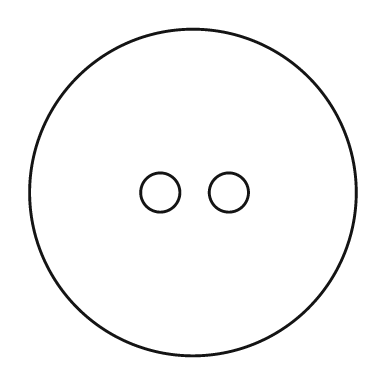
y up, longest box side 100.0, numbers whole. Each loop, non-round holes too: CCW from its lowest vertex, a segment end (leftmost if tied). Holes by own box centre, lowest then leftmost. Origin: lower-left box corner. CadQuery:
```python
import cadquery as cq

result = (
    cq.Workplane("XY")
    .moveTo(50.0, 50.0)
    .circle(50.0)
    .moveTo(40.0, 50.0)
    .circle(6.0)
    .moveTo(61.0, 50.0)
    .circle(6.0)
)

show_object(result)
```